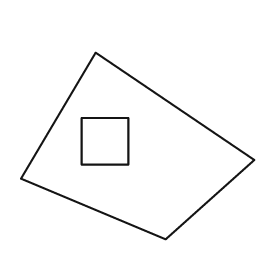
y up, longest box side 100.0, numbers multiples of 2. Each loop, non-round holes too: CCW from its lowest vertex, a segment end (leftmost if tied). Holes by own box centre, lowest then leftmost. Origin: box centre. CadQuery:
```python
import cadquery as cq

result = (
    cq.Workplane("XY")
    .moveTo(12.0, -40.0)
    .lineTo(50.0, -6.0)
    .lineTo(-18.0, 40.0)
    .lineTo(-50.0, -14.0)
    .close()
    .moveTo(-24.0, -8.0)
    .lineTo(-4.0, -8.0)
    .lineTo(-4.0, 12.0)
    .lineTo(-24.0, 12.0)
    .close()
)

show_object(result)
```